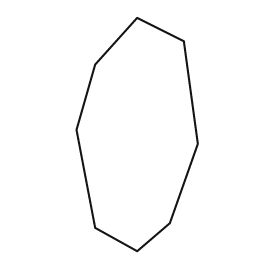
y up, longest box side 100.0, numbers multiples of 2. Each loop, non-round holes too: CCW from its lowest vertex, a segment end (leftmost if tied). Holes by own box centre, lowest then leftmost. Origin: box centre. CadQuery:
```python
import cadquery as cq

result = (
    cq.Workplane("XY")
    .moveTo(0.0, -50.0)
    .lineTo(14.0, -38.0)
    .lineTo(26.0, -4.0)
    .lineTo(20.0, 40.0)
    .lineTo(0.0, 50.0)
    .lineTo(-18.0, 30.0)
    .lineTo(-26.0, 2.0)
    .lineTo(-18.0, -40.0)
    .close()
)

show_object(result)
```